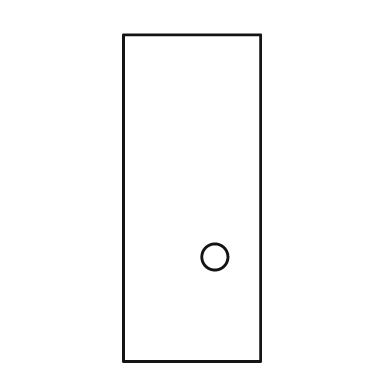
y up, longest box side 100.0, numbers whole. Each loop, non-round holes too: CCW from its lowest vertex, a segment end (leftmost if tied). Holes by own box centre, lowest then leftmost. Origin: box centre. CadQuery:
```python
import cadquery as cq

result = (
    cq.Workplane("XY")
    .moveTo(-21.0, -50.0)
    .lineTo(21.0, -50.0)
    .lineTo(21.0, 50.0)
    .lineTo(-21.0, 50.0)
    .close()
    .moveTo(7.0, -18.0)
    .circle(4.0)
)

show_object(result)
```